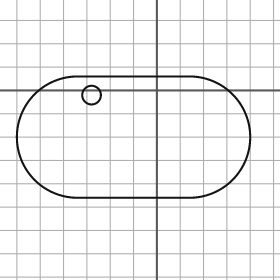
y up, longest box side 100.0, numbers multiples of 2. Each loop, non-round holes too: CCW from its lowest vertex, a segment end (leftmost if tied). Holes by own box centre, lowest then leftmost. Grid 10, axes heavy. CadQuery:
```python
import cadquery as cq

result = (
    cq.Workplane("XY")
    .moveTo(-34.0, -46.0)
    .lineTo(14.0, -46.0)
    .threePointArc((40.0, -20.0), (14.0, 6.0))
    .lineTo(-34.0, 6.0)
    .threePointArc((-60.0, -20.0), (-34.0, -46.0))
    .close()
    .moveTo(-28.0, -2.0)
    .circle(4.0)
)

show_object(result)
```